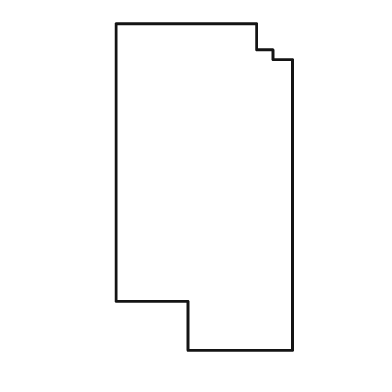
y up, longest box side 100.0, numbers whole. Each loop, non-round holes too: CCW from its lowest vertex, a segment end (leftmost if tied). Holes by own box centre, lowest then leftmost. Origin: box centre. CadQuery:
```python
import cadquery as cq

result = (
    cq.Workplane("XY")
    .moveTo(-5.0, -50.0)
    .lineTo(27.0, -50.0)
    .lineTo(27.0, 39.0)
    .lineTo(21.0, 39.0)
    .lineTo(21.0, 42.0)
    .lineTo(16.0, 42.0)
    .lineTo(16.0, 50.0)
    .lineTo(-27.0, 50.0)
    .lineTo(-27.0, -35.0)
    .lineTo(-5.0, -35.0)
    .close()
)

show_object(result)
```